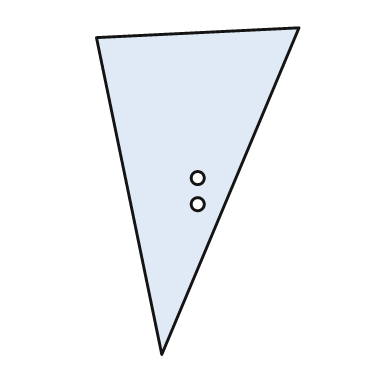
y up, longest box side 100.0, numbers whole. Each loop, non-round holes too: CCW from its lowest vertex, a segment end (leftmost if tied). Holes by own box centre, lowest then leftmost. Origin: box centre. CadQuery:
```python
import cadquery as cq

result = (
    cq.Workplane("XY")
    .moveTo(-11.0, -50.0)
    .lineTo(31.0, 50.0)
    .lineTo(-31.0, 47.0)
    .close()
    .moveTo(0.0, -4.0)
    .circle(2.0)
    .moveTo(0.0, 4.0)
    .circle(2.0)
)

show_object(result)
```